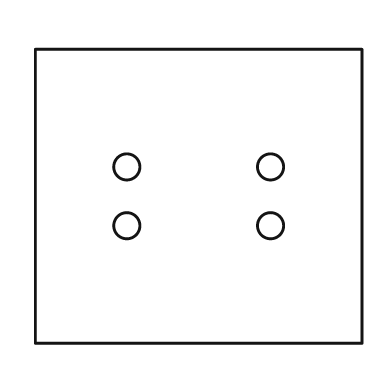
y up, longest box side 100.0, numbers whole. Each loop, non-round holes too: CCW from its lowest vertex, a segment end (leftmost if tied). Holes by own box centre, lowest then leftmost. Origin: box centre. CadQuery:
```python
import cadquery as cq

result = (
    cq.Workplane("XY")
    .moveTo(-50.0, -45.0)
    .lineTo(50.0, -45.0)
    .lineTo(50.0, 45.0)
    .lineTo(-50.0, 45.0)
    .close()
    .moveTo(-22.0, -9.0)
    .circle(4.0)
    .moveTo(22.0, -9.0)
    .circle(4.0)
    .moveTo(-22.0, 9.0)
    .circle(4.0)
    .moveTo(22.0, 9.0)
    .circle(4.0)
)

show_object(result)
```